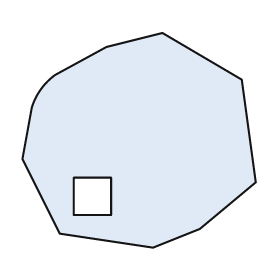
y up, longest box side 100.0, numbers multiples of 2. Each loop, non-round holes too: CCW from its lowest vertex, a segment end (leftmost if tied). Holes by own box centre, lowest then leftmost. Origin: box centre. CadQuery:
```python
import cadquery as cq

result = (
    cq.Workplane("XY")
    .moveTo(6.0, -46.0)
    .lineTo(26.0, -38.0)
    .lineTo(50.0, -18.0)
    .lineTo(44.0, 26.0)
    .lineTo(10.0, 46.0)
    .lineTo(-14.0, 40.0)
    .lineTo(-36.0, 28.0)
    .threePointArc((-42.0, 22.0), (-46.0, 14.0))
    .lineTo(-50.0, -8.0)
    .lineTo(-34.0, -40.0)
    .close()
    .moveTo(-28.0, -32.0)
    .lineTo(-12.0, -32.0)
    .lineTo(-12.0, -16.0)
    .lineTo(-28.0, -16.0)
    .close()
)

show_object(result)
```